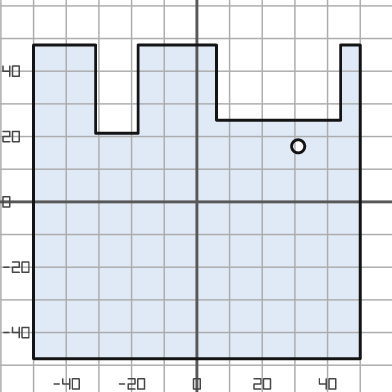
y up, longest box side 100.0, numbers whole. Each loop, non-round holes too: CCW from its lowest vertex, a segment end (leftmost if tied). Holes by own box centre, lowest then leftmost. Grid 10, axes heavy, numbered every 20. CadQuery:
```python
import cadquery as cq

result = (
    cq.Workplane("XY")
    .moveTo(-50.0, -48.0)
    .lineTo(50.0, -48.0)
    .lineTo(50.0, 48.0)
    .lineTo(44.0, 48.0)
    .lineTo(44.0, 25.0)
    .lineTo(6.0, 25.0)
    .lineTo(6.0, 48.0)
    .lineTo(-18.0, 48.0)
    .lineTo(-18.0, 21.0)
    .lineTo(-31.0, 21.0)
    .lineTo(-31.0, 48.0)
    .lineTo(-50.0, 48.0)
    .close()
    .moveTo(31.0, 17.0)
    .circle(2.0)
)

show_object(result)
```